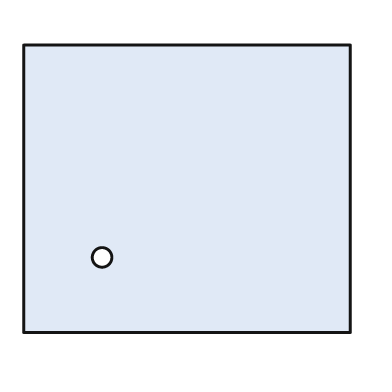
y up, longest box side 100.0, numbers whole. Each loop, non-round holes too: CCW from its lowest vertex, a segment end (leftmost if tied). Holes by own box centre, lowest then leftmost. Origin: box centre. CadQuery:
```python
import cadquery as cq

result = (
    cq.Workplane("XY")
    .moveTo(-50.0, -44.0)
    .lineTo(50.0, -44.0)
    .lineTo(50.0, 44.0)
    .lineTo(-50.0, 44.0)
    .close()
    .moveTo(-26.0, -21.0)
    .circle(3.0)
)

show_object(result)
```